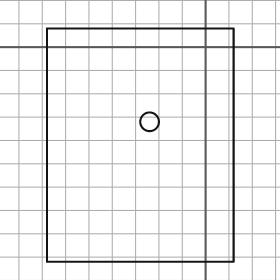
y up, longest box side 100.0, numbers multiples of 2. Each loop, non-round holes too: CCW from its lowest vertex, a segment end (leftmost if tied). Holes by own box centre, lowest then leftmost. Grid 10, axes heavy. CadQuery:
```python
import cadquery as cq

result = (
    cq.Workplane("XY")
    .moveTo(-68.0, -92.0)
    .lineTo(12.0, -92.0)
    .lineTo(12.0, 8.0)
    .lineTo(-68.0, 8.0)
    .close()
    .moveTo(-24.0, -32.0)
    .circle(4.0)
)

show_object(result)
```